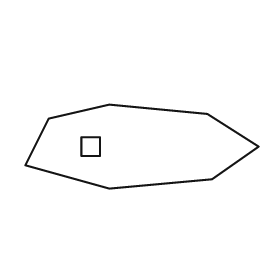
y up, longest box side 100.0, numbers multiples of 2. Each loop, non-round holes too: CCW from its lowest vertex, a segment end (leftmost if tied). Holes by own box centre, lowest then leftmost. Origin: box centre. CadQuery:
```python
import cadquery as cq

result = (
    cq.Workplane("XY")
    .moveTo(-14.0, -18.0)
    .lineTo(30.0, -14.0)
    .lineTo(50.0, 0.0)
    .lineTo(28.0, 14.0)
    .lineTo(-14.0, 18.0)
    .lineTo(-40.0, 12.0)
    .lineTo(-50.0, -8.0)
    .close()
    .moveTo(-26.0, -4.0)
    .lineTo(-18.0, -4.0)
    .lineTo(-18.0, 4.0)
    .lineTo(-26.0, 4.0)
    .close()
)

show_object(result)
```